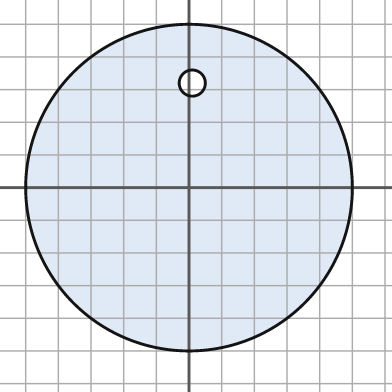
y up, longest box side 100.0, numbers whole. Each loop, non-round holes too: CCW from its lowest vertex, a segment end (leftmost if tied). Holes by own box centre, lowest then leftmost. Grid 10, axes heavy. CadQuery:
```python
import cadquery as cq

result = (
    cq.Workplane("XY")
    .moveTo(0.0, 0.0)
    .circle(50.0)
    .moveTo(1.0, 32.0)
    .circle(4.0)
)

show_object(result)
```